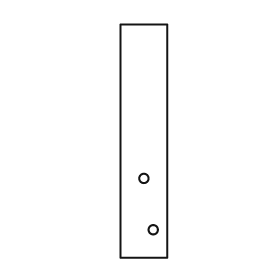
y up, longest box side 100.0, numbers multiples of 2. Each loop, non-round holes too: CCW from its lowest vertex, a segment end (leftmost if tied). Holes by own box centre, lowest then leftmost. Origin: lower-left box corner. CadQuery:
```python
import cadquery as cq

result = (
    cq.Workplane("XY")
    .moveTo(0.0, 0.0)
    .lineTo(20.0, 0.0)
    .lineTo(20.0, 100.0)
    .lineTo(0.0, 100.0)
    .close()
    .moveTo(14.0, 12.0)
    .circle(2.0)
    .moveTo(10.0, 34.0)
    .circle(2.0)
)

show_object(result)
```